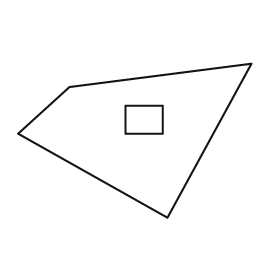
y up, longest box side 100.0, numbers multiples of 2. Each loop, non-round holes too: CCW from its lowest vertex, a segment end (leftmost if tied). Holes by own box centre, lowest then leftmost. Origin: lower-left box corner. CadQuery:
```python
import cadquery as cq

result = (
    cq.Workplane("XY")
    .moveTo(64.0, 0.0)
    .lineTo(100.0, 66.0)
    .lineTo(22.0, 56.0)
    .lineTo(0.0, 36.0)
    .close()
    .moveTo(46.0, 36.0)
    .lineTo(62.0, 36.0)
    .lineTo(62.0, 48.0)
    .lineTo(46.0, 48.0)
    .close()
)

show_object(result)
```